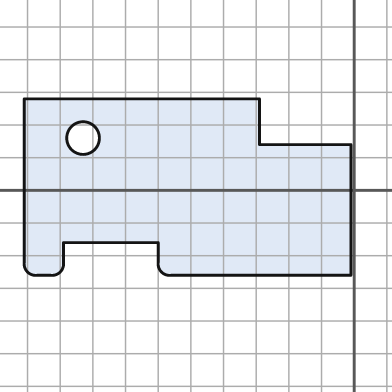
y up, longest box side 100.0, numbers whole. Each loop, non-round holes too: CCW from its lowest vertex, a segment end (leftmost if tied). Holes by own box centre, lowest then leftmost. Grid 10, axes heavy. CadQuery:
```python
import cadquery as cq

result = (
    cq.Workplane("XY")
    .moveTo(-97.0, -26.0)
    .lineTo(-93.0, -26.0)
    .threePointArc((-90.0, -25.0), (-89.0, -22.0))
    .lineTo(-89.0, -16.0)
    .lineTo(-60.0, -16.0)
    .lineTo(-60.0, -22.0)
    .threePointArc((-59.0, -25.0), (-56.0, -26.0))
    .lineTo(-1.0, -26.0)
    .lineTo(-1.0, 14.0)
    .lineTo(-29.0, 14.0)
    .lineTo(-29.0, 28.0)
    .lineTo(-101.0, 28.0)
    .lineTo(-101.0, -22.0)
    .threePointArc((-100.0, -25.0), (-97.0, -26.0))
    .close()
    .moveTo(-83.0, 16.0)
    .circle(5.0)
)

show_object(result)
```